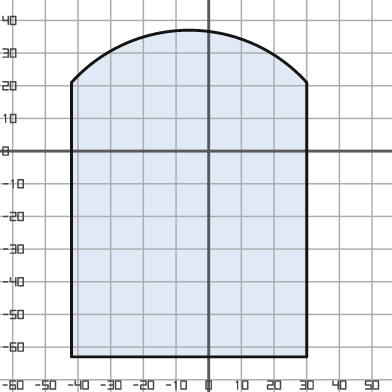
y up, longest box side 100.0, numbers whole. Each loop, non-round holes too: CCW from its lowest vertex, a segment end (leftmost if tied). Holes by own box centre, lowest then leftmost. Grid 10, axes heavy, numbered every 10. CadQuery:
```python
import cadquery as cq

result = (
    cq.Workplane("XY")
    .moveTo(-42.0, -63.0)
    .lineTo(30.0, -63.0)
    .lineTo(30.0, 21.0)
    .threePointArc((-6.0, 37.0), (-42.0, 21.0))
    .close()
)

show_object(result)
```